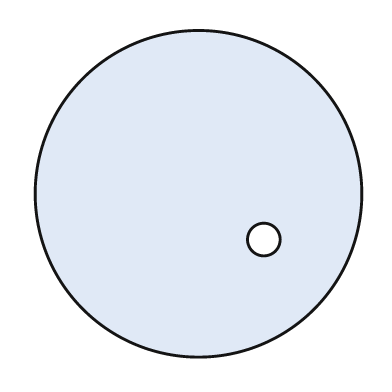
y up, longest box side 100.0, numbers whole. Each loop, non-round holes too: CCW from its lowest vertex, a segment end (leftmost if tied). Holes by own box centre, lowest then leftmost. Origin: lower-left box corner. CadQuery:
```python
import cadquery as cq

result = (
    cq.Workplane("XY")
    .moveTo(50.0, 50.0)
    .circle(50.0)
    .moveTo(70.0, 36.0)
    .circle(5.0)
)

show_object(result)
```